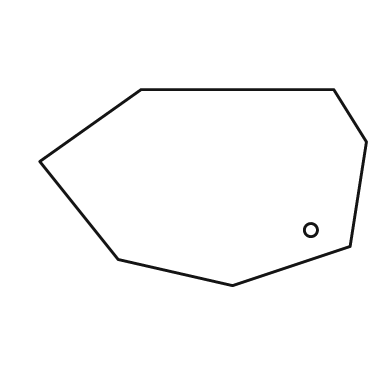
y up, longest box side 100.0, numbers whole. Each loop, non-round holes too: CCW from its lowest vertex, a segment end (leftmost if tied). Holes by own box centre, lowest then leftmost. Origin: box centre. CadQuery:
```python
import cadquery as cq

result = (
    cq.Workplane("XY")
    .moveTo(9.0, -30.0)
    .lineTo(45.0, -18.0)
    .lineTo(50.0, 14.0)
    .lineTo(40.0, 30.0)
    .lineTo(-19.0, 30.0)
    .lineTo(-50.0, 8.0)
    .lineTo(-26.0, -22.0)
    .close()
    .moveTo(33.0, -13.0)
    .circle(2.0)
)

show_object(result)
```